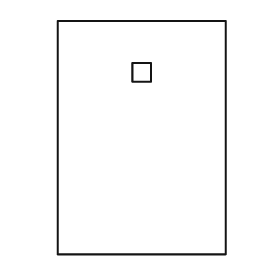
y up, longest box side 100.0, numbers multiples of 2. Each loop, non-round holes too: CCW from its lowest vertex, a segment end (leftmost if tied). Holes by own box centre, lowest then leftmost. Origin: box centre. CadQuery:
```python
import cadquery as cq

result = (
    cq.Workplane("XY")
    .moveTo(-36.0, -50.0)
    .lineTo(36.0, -50.0)
    .lineTo(36.0, 50.0)
    .lineTo(-36.0, 50.0)
    .close()
    .moveTo(-4.0, 24.0)
    .lineTo(4.0, 24.0)
    .lineTo(4.0, 32.0)
    .lineTo(-4.0, 32.0)
    .close()
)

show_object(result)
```